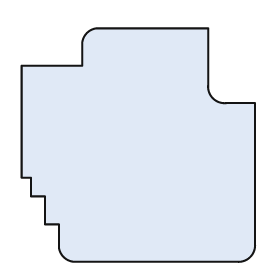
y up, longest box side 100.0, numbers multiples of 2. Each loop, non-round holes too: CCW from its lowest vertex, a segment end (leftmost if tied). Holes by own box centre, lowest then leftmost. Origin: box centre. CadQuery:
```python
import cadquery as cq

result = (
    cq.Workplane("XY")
    .moveTo(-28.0, -50.0)
    .lineTo(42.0, -50.0)
    .threePointArc((48.0, -48.0), (50.0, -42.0))
    .lineTo(50.0, 18.0)
    .lineTo(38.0, 18.0)
    .threePointArc((32.0, 20.0), (30.0, 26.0))
    .lineTo(30.0, 50.0)
    .lineTo(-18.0, 50.0)
    .threePointArc((-22.0, 48.0), (-24.0, 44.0))
    .lineTo(-24.0, 34.0)
    .lineTo(-50.0, 34.0)
    .lineTo(-50.0, -14.0)
    .lineTo(-46.0, -14.0)
    .lineTo(-46.0, -22.0)
    .lineTo(-40.0, -22.0)
    .lineTo(-40.0, -34.0)
    .lineTo(-34.0, -34.0)
    .lineTo(-34.0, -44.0)
    .threePointArc((-32.0, -48.0), (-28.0, -50.0))
    .close()
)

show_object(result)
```